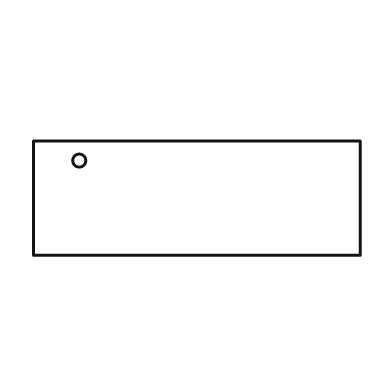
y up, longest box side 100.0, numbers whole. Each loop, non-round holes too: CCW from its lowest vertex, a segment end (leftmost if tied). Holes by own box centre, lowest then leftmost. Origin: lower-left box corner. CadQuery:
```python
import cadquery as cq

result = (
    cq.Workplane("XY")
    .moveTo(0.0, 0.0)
    .lineTo(100.0, 0.0)
    .lineTo(100.0, 35.0)
    .lineTo(0.0, 35.0)
    .close()
    .moveTo(14.0, 29.0)
    .circle(2.0)
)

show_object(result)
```